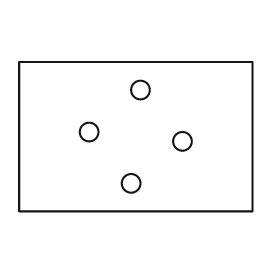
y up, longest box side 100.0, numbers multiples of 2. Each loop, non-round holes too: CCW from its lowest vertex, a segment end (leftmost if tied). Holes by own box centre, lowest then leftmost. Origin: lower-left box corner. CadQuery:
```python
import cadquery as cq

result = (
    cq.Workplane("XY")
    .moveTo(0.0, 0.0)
    .lineTo(100.0, 0.0)
    .lineTo(100.0, 64.0)
    .lineTo(0.0, 64.0)
    .close()
    .moveTo(48.0, 12.0)
    .circle(4.0)
    .moveTo(70.0, 30.0)
    .circle(4.0)
    .moveTo(30.0, 34.0)
    .circle(4.0)
    .moveTo(52.0, 52.0)
    .circle(4.0)
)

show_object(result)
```